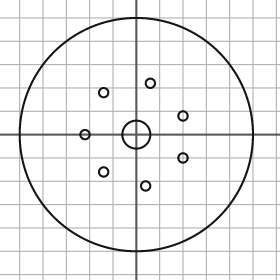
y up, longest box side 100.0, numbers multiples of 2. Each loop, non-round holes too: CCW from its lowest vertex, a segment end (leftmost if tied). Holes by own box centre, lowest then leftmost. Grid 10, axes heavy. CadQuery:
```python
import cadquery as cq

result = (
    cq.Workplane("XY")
    .moveTo(0.0, 0.0)
    .circle(50.0)
    .moveTo(4.0, -22.0)
    .circle(2.0)
    .moveTo(-14.0, -16.0)
    .circle(2.0)
    .moveTo(20.0, -10.0)
    .circle(2.0)
    .moveTo(-22.0, 0.0)
    .circle(2.0)
    .moveTo(0.0, 0.0)
    .circle(6.0)
    .moveTo(20.0, 8.0)
    .circle(2.0)
    .moveTo(-14.0, 18.0)
    .circle(2.0)
    .moveTo(6.0, 22.0)
    .circle(2.0)
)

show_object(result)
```